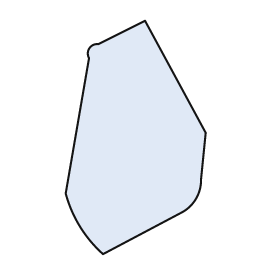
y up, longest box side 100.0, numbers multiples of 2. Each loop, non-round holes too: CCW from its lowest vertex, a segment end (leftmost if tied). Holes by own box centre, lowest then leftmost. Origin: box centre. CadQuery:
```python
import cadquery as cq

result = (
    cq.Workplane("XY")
    .moveTo(-14.0, -50.0)
    .lineTo(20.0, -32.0)
    .threePointArc((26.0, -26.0), (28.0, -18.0))
    .lineTo(30.0, 2.0)
    .lineTo(4.0, 50.0)
    .lineTo(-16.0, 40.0)
    .threePointArc((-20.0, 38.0), (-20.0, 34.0))
    .lineTo(-30.0, -24.0)
    .threePointArc((-24.0, -38.0), (-14.0, -50.0))
    .close()
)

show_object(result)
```